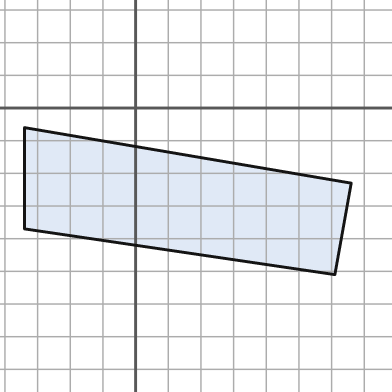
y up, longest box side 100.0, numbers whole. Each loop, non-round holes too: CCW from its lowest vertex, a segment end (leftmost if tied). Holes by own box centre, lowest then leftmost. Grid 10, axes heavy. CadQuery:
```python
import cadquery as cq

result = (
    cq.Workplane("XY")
    .moveTo(61.0, -51.0)
    .lineTo(66.0, -23.0)
    .lineTo(-34.0, -6.0)
    .lineTo(-34.0, -37.0)
    .close()
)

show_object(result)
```